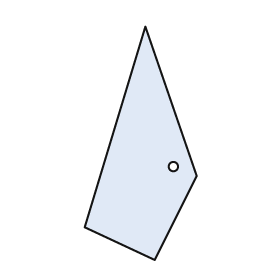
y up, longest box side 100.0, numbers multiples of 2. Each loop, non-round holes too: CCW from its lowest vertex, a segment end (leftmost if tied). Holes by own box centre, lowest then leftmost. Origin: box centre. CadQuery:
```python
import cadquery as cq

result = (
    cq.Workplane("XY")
    .moveTo(6.0, -50.0)
    .lineTo(24.0, -14.0)
    .lineTo(2.0, 50.0)
    .lineTo(-24.0, -36.0)
    .close()
    .moveTo(14.0, -10.0)
    .circle(2.0)
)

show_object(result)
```